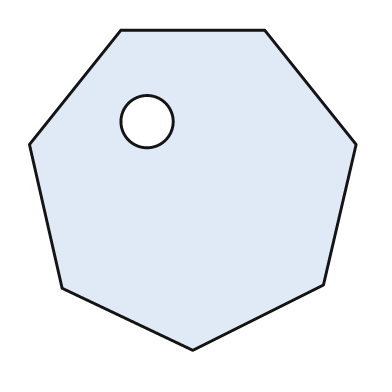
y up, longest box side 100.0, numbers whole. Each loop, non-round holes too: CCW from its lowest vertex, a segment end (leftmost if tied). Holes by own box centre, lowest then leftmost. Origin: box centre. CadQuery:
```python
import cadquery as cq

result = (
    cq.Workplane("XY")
    .moveTo(0.0, -49.0)
    .lineTo(40.0, -29.0)
    .lineTo(50.0, 14.0)
    .lineTo(22.0, 49.0)
    .lineTo(-22.0, 49.0)
    .lineTo(-50.0, 14.0)
    .lineTo(-40.0, -30.0)
    .close()
    .moveTo(-14.0, 21.0)
    .circle(8.0)
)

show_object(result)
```